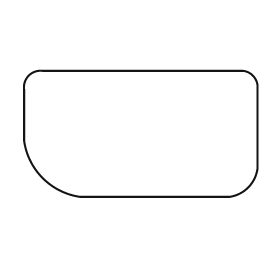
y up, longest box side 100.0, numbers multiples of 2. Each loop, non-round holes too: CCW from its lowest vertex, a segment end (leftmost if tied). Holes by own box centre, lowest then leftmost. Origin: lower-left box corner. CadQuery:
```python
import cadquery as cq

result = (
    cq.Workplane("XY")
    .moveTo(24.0, 0.0)
    .lineTo(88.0, 0.0)
    .threePointArc((96.0, 4.0), (100.0, 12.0))
    .lineTo(100.0, 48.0)
    .threePointArc((98.0, 52.0), (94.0, 54.0))
    .lineTo(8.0, 54.0)
    .threePointArc((2.0, 52.0), (0.0, 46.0))
    .lineTo(0.0, 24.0)
    .threePointArc((8.0, 8.0), (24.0, 0.0))
    .close()
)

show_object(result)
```